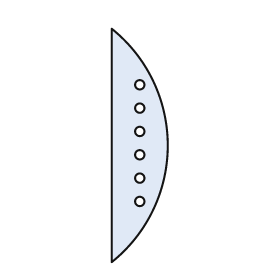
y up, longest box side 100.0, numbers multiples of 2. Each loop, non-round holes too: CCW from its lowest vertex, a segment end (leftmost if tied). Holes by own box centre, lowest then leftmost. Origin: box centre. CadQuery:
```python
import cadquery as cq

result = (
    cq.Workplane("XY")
    .moveTo(-12.0, -50.0)
    .threePointArc((12.0, 0.0), (-12.0, 50.0))
    .close()
    .moveTo(0.0, -24.0)
    .circle(2.0)
    .moveTo(0.0, -14.0)
    .circle(2.0)
    .moveTo(0.0, -4.0)
    .circle(2.0)
    .moveTo(0.0, 6.0)
    .circle(2.0)
    .moveTo(0.0, 16.0)
    .circle(2.0)
    .moveTo(0.0, 26.0)
    .circle(2.0)
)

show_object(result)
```